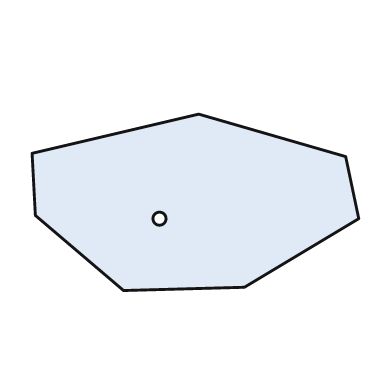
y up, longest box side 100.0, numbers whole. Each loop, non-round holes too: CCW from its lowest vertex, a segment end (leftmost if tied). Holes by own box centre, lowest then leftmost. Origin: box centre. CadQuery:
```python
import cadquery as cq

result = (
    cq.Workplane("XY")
    .moveTo(-22.0, -27.0)
    .lineTo(15.0, -26.0)
    .lineTo(50.0, -5.0)
    .lineTo(46.0, 14.0)
    .lineTo(1.0, 27.0)
    .lineTo(-50.0, 15.0)
    .lineTo(-49.0, -4.0)
    .close()
    .moveTo(-11.0, -5.0)
    .circle(2.0)
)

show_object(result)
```